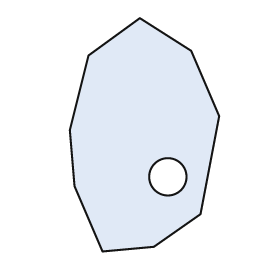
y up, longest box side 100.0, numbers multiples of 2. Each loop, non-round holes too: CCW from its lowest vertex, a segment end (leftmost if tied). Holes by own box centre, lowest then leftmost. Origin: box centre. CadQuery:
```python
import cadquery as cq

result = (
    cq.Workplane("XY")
    .moveTo(-18.0, -50.0)
    .lineTo(4.0, -48.0)
    .lineTo(24.0, -34.0)
    .lineTo(32.0, 8.0)
    .lineTo(20.0, 36.0)
    .lineTo(-2.0, 50.0)
    .lineTo(-24.0, 34.0)
    .lineTo(-32.0, 2.0)
    .lineTo(-30.0, -22.0)
    .close()
    .moveTo(10.0, -18.0)
    .circle(8.0)
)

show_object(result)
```